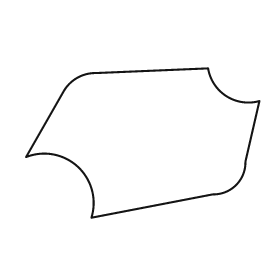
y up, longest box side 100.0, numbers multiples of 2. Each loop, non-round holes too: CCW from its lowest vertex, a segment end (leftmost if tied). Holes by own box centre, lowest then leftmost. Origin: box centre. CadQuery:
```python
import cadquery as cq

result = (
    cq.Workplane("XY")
    .moveTo(-22.0, -32.0)
    .lineTo(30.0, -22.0)
    .threePointArc((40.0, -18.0), (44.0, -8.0))
    .lineTo(50.0, 18.0)
    .threePointArc((36.0, 20.0), (28.0, 32.0))
    .lineTo(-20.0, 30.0)
    .threePointArc((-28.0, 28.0), (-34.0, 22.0))
    .lineTo(-50.0, -6.0)
    .threePointArc((-28.0, -10.0), (-22.0, -32.0))
    .close()
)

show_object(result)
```